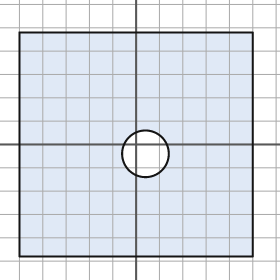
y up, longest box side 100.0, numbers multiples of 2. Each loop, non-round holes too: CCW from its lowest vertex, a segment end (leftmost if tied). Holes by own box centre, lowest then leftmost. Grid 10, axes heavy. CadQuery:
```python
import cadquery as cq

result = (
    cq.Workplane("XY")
    .moveTo(-50.0, -48.0)
    .lineTo(50.0, -48.0)
    .lineTo(50.0, 48.0)
    .lineTo(-50.0, 48.0)
    .close()
    .moveTo(4.0, -4.0)
    .circle(10.0)
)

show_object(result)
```